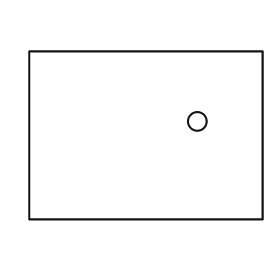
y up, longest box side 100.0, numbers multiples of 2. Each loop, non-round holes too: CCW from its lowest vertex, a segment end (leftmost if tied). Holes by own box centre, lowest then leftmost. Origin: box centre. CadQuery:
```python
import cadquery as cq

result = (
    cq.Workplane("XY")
    .moveTo(-50.0, -36.0)
    .lineTo(50.0, -36.0)
    .lineTo(50.0, 36.0)
    .lineTo(-50.0, 36.0)
    .close()
    .moveTo(22.0, 6.0)
    .circle(4.0)
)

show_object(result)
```